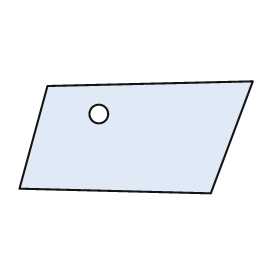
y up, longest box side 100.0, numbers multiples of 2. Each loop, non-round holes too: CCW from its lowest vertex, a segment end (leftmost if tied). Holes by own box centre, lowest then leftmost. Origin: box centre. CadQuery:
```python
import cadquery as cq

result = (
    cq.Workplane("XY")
    .moveTo(32.0, -24.0)
    .lineTo(50.0, 24.0)
    .lineTo(-38.0, 22.0)
    .lineTo(-50.0, -22.0)
    .close()
    .moveTo(-16.0, 10.0)
    .circle(4.0)
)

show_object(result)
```